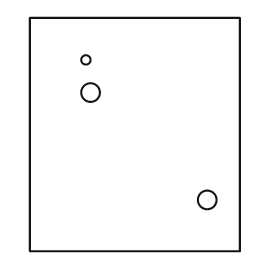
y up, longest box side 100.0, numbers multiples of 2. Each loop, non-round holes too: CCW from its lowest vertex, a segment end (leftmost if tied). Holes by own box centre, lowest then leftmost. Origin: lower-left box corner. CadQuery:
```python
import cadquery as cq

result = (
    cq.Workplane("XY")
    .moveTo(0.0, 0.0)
    .lineTo(90.0, 0.0)
    .lineTo(90.0, 100.0)
    .lineTo(0.0, 100.0)
    .close()
    .moveTo(76.0, 22.0)
    .circle(4.0)
    .moveTo(26.0, 68.0)
    .circle(4.0)
    .moveTo(24.0, 82.0)
    .circle(2.0)
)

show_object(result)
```